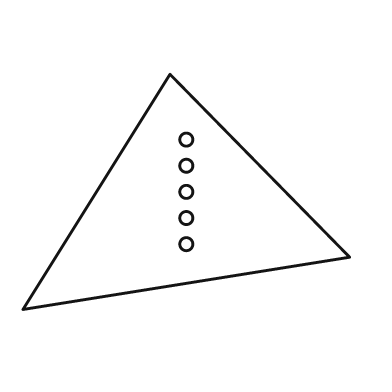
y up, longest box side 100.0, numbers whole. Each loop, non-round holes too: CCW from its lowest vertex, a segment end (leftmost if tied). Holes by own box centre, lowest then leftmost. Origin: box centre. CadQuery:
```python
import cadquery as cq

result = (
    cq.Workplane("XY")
    .moveTo(-50.0, -36.0)
    .lineTo(50.0, -20.0)
    .lineTo(-5.0, 36.0)
    .close()
    .moveTo(0.0, -16.0)
    .circle(2.0)
    .moveTo(0.0, -8.0)
    .circle(2.0)
    .moveTo(0.0, 0.0)
    .circle(2.0)
    .moveTo(0.0, 8.0)
    .circle(2.0)
    .moveTo(0.0, 16.0)
    .circle(2.0)
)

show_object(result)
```